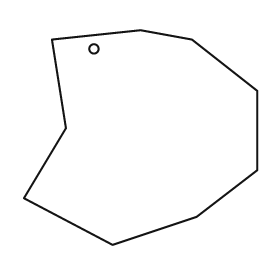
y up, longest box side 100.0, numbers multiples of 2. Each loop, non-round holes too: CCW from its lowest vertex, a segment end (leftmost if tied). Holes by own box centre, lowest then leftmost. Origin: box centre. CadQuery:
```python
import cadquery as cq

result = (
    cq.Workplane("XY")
    .moveTo(-12.0, -46.0)
    .lineTo(24.0, -34.0)
    .lineTo(50.0, -14.0)
    .lineTo(50.0, 20.0)
    .lineTo(22.0, 42.0)
    .lineTo(0.0, 46.0)
    .lineTo(-38.0, 42.0)
    .lineTo(-32.0, 4.0)
    .lineTo(-50.0, -26.0)
    .close()
    .moveTo(-20.0, 38.0)
    .circle(2.0)
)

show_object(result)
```